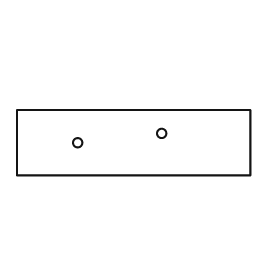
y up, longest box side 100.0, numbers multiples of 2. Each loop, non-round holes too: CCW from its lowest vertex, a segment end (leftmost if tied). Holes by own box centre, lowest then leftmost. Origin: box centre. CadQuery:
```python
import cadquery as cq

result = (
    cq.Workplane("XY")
    .moveTo(-50.0, -14.0)
    .lineTo(50.0, -14.0)
    .lineTo(50.0, 14.0)
    .lineTo(-50.0, 14.0)
    .close()
    .moveTo(-24.0, 0.0)
    .circle(2.0)
    .moveTo(12.0, 4.0)
    .circle(2.0)
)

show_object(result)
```